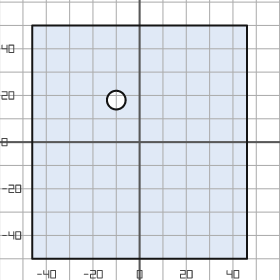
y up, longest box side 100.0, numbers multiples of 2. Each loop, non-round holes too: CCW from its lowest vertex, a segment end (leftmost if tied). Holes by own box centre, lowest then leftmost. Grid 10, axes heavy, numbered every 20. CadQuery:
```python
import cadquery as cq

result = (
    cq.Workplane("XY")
    .moveTo(-46.0, -50.0)
    .lineTo(46.0, -50.0)
    .lineTo(46.0, 50.0)
    .lineTo(-46.0, 50.0)
    .close()
    .moveTo(-10.0, 18.0)
    .circle(4.0)
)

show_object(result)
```